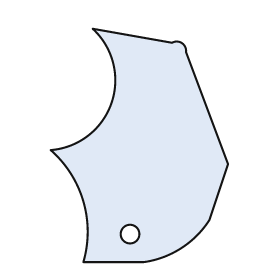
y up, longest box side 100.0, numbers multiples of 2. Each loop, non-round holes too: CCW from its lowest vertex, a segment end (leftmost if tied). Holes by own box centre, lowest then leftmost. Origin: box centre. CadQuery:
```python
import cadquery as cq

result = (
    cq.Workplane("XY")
    .moveTo(-24.0, -50.0)
    .lineTo(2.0, -50.0)
    .threePointArc((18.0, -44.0), (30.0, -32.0))
    .lineTo(38.0, -8.0)
    .lineTo(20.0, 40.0)
    .threePointArc((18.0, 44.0), (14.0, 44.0))
    .lineTo(-20.0, 50.0)
    .threePointArc((-12.0, 18.0), (-38.0, -2.0))
    .threePointArc((-24.0, -24.0), (-24.0, -50.0))
    .close()
    .moveTo(-4.0, -38.0)
    .circle(4.0)
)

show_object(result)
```